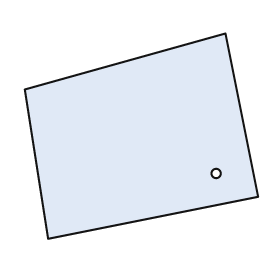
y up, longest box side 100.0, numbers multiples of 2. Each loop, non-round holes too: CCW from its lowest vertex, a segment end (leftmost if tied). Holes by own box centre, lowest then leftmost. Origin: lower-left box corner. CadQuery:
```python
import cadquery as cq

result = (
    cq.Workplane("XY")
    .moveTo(10.0, 0.0)
    .lineTo(100.0, 18.0)
    .lineTo(86.0, 88.0)
    .lineTo(0.0, 64.0)
    .close()
    .moveTo(82.0, 28.0)
    .circle(2.0)
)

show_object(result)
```